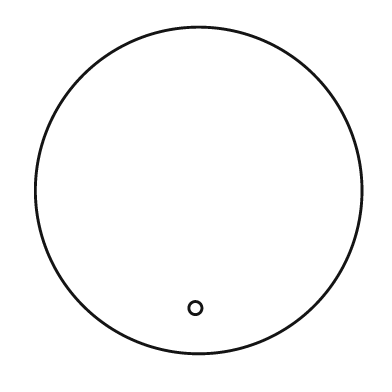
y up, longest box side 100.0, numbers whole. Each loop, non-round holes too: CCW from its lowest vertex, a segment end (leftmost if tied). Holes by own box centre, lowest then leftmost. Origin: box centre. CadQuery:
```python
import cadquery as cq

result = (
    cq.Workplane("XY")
    .moveTo(0.0, 0.0)
    .circle(50.0)
    .moveTo(-1.0, -36.0)
    .circle(2.0)
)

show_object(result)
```